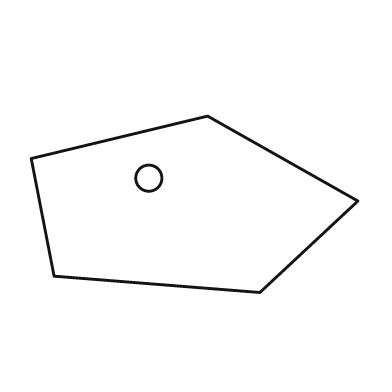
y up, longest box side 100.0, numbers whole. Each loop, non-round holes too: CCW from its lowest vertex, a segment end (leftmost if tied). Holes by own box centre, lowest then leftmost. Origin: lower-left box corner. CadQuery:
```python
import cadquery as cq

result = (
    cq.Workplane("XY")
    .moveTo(70.0, 0.0)
    .lineTo(100.0, 28.0)
    .lineTo(54.0, 54.0)
    .lineTo(0.0, 41.0)
    .lineTo(7.0, 5.0)
    .close()
    .moveTo(36.0, 35.0)
    .circle(4.0)
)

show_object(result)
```